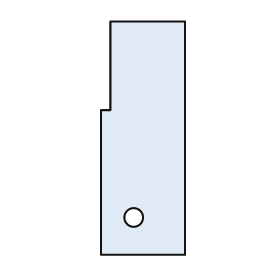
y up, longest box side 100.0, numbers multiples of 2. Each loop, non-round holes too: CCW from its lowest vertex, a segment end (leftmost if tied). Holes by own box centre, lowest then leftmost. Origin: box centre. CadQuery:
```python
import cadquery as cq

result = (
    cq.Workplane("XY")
    .moveTo(-18.0, -50.0)
    .lineTo(18.0, -50.0)
    .lineTo(18.0, 50.0)
    .lineTo(-14.0, 50.0)
    .lineTo(-14.0, 12.0)
    .lineTo(-18.0, 12.0)
    .close()
    .moveTo(-4.0, -34.0)
    .circle(4.0)
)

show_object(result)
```